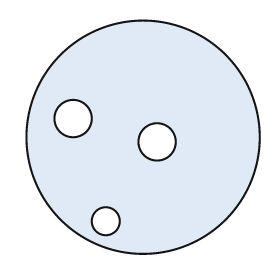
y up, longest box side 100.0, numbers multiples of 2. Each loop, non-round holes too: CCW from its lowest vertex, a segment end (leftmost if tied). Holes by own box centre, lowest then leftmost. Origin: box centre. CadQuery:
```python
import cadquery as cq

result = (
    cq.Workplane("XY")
    .moveTo(0.0, 0.0)
    .circle(50.0)
    .moveTo(-16.0, -36.0)
    .circle(6.0)
    .moveTo(6.0, -2.0)
    .circle(8.0)
    .moveTo(-30.0, 8.0)
    .circle(8.0)
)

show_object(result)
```